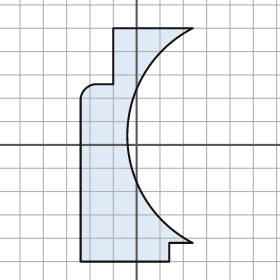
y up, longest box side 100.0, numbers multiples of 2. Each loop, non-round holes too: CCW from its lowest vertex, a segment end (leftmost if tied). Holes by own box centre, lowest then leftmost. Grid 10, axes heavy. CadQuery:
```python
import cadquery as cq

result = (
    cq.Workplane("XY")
    .moveTo(-24.0, -50.0)
    .lineTo(14.0, -50.0)
    .lineTo(14.0, -42.0)
    .lineTo(24.0, -42.0)
    .threePointArc((-4.0, 4.0), (24.0, 50.0))
    .lineTo(-10.0, 50.0)
    .lineTo(-10.0, 26.0)
    .lineTo(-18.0, 26.0)
    .threePointArc((-22.0, 24.0), (-24.0, 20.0))
    .close()
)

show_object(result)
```